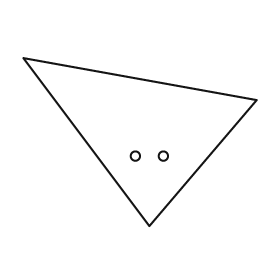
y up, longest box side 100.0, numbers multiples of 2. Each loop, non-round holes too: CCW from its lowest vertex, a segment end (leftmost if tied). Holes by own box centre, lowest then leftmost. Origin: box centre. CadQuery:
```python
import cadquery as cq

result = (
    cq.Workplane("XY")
    .moveTo(4.0, -36.0)
    .lineTo(50.0, 18.0)
    .lineTo(-50.0, 36.0)
    .close()
    .moveTo(-2.0, -6.0)
    .circle(2.0)
    .moveTo(10.0, -6.0)
    .circle(2.0)
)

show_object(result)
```